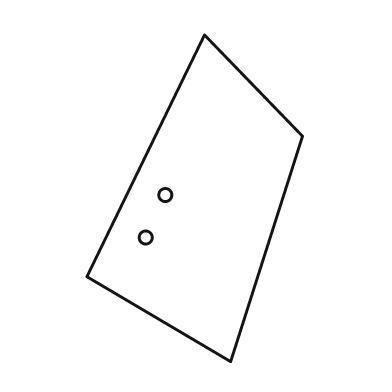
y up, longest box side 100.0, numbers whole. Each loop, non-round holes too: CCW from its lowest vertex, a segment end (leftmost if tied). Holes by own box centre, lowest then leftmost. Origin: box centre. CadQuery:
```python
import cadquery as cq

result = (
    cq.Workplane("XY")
    .moveTo(11.0, -50.0)
    .lineTo(33.0, 19.0)
    .lineTo(3.0, 50.0)
    .lineTo(-33.0, -24.0)
    .close()
    .moveTo(-15.0, -12.0)
    .circle(2.0)
    .moveTo(-9.0, 1.0)
    .circle(2.0)
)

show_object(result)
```